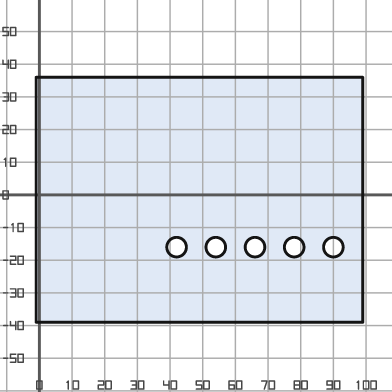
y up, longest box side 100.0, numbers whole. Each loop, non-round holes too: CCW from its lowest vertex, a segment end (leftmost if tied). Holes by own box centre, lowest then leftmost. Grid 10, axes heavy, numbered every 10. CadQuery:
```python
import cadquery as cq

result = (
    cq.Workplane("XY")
    .moveTo(-1.0, -39.0)
    .lineTo(99.0, -39.0)
    .lineTo(99.0, 36.0)
    .lineTo(-1.0, 36.0)
    .close()
    .moveTo(42.0, -16.0)
    .circle(3.0)
    .moveTo(54.0, -16.0)
    .circle(3.0)
    .moveTo(66.0, -16.0)
    .circle(3.0)
    .moveTo(78.0, -16.0)
    .circle(3.0)
    .moveTo(90.0, -16.0)
    .circle(3.0)
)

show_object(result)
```